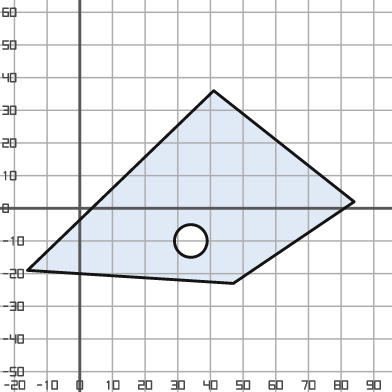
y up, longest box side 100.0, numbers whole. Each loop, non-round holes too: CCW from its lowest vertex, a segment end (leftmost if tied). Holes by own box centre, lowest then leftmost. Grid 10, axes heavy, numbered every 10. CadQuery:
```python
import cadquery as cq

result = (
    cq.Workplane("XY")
    .moveTo(47.0, -23.0)
    .lineTo(84.0, 2.0)
    .lineTo(41.0, 36.0)
    .lineTo(-16.0, -19.0)
    .close()
    .moveTo(34.0, -10.0)
    .circle(5.0)
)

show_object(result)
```